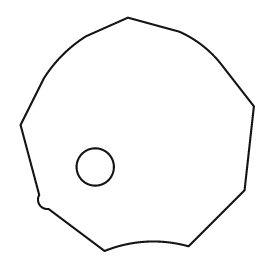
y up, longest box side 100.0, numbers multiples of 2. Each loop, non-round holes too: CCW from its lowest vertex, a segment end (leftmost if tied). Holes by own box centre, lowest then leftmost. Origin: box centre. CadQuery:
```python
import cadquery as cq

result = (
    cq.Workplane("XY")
    .moveTo(-14.0, -50.0)
    .threePointArc((4.0, -46.0), (22.0, -48.0))
    .lineTo(46.0, -24.0)
    .lineTo(50.0, 12.0)
    .lineTo(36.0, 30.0)
    .threePointArc((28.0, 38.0), (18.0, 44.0))
    .lineTo(-4.0, 50.0)
    .lineTo(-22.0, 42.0)
    .threePointArc((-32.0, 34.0), (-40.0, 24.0))
    .lineTo(-50.0, 4.0)
    .lineTo(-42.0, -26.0)
    .threePointArc((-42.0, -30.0), (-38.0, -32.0))
    .close()
    .moveTo(-18.0, -14.0)
    .circle(8.0)
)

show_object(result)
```